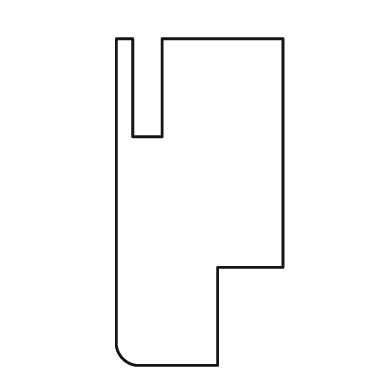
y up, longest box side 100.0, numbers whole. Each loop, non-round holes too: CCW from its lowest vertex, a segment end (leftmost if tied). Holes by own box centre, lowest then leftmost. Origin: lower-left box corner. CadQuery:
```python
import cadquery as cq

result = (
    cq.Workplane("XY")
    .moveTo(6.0, 0.0)
    .lineTo(31.0, 0.0)
    .lineTo(31.0, 30.0)
    .lineTo(51.0, 30.0)
    .lineTo(51.0, 100.0)
    .lineTo(14.0, 100.0)
    .lineTo(14.0, 70.0)
    .lineTo(5.0, 70.0)
    .lineTo(5.0, 100.0)
    .lineTo(0.0, 100.0)
    .lineTo(0.0, 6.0)
    .threePointArc((2.0, 2.0), (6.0, 0.0))
    .close()
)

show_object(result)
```